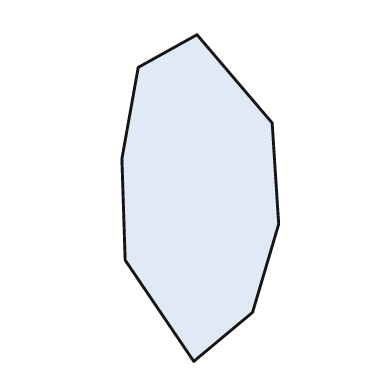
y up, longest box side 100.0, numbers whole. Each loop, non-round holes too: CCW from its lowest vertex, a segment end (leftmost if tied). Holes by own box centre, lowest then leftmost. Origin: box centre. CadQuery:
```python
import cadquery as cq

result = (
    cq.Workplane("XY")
    .moveTo(-2.0, -50.0)
    .lineTo(16.0, -35.0)
    .lineTo(24.0, -8.0)
    .lineTo(22.0, 23.0)
    .lineTo(-1.0, 50.0)
    .lineTo(-19.0, 40.0)
    .lineTo(-24.0, 12.0)
    .lineTo(-23.0, -19.0)
    .close()
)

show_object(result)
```